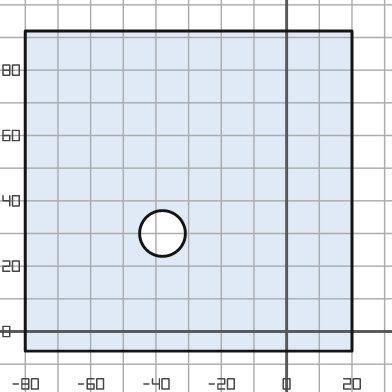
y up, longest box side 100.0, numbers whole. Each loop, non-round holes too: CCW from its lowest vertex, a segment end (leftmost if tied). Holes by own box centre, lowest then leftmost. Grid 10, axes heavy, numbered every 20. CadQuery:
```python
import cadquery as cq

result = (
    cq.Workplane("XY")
    .moveTo(-80.0, -6.0)
    .lineTo(20.0, -6.0)
    .lineTo(20.0, 92.0)
    .lineTo(-80.0, 92.0)
    .close()
    .moveTo(-38.0, 30.0)
    .circle(7.0)
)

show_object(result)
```